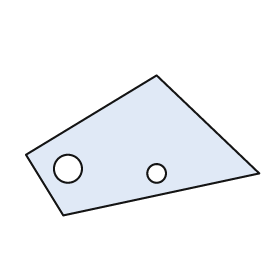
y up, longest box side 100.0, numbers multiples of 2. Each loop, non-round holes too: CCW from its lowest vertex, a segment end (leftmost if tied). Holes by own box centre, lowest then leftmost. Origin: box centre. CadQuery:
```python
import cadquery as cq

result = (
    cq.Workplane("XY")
    .moveTo(-34.0, -30.0)
    .lineTo(50.0, -12.0)
    .lineTo(6.0, 30.0)
    .lineTo(-50.0, -4.0)
    .close()
    .moveTo(6.0, -12.0)
    .circle(4.0)
    .moveTo(-32.0, -10.0)
    .circle(6.0)
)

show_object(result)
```